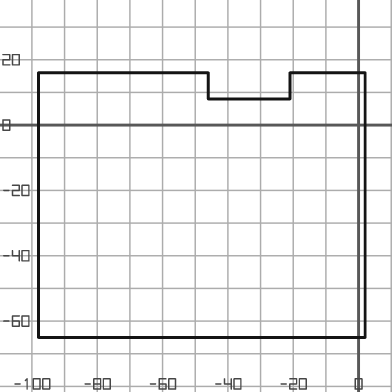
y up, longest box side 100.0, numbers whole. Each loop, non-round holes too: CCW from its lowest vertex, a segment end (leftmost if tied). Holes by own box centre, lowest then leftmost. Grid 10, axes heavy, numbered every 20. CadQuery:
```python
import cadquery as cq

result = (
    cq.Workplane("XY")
    .moveTo(-98.0, -65.0)
    .lineTo(2.0, -65.0)
    .lineTo(2.0, 16.0)
    .lineTo(-21.0, 16.0)
    .lineTo(-21.0, 8.0)
    .lineTo(-46.0, 8.0)
    .lineTo(-46.0, 16.0)
    .lineTo(-98.0, 16.0)
    .close()
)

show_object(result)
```